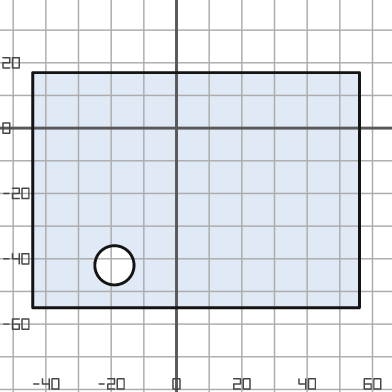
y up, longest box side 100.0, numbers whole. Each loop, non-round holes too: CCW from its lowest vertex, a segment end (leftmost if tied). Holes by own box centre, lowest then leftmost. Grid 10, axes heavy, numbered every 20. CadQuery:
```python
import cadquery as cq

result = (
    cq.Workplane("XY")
    .moveTo(-44.0, -55.0)
    .lineTo(56.0, -55.0)
    .lineTo(56.0, 17.0)
    .lineTo(-44.0, 17.0)
    .close()
    .moveTo(-19.0, -42.0)
    .circle(6.0)
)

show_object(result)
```